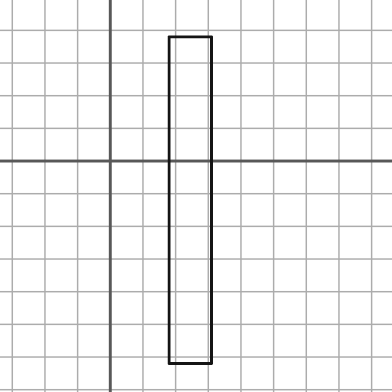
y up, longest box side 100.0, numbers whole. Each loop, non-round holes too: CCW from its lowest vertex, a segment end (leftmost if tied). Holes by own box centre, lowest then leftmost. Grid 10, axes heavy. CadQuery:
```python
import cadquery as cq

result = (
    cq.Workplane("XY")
    .moveTo(18.0, -62.0)
    .lineTo(31.0, -62.0)
    .lineTo(31.0, 38.0)
    .lineTo(18.0, 38.0)
    .close()
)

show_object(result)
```